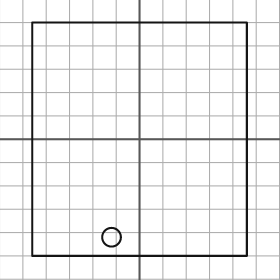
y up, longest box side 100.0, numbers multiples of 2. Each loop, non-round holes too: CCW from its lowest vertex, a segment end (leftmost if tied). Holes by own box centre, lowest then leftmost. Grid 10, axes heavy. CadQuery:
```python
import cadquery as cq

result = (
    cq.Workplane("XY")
    .moveTo(-46.0, -50.0)
    .lineTo(46.0, -50.0)
    .lineTo(46.0, 50.0)
    .lineTo(-46.0, 50.0)
    .close()
    .moveTo(-12.0, -42.0)
    .circle(4.0)
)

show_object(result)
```